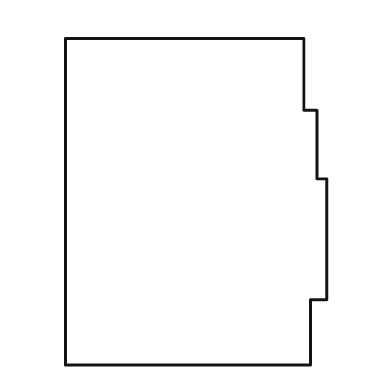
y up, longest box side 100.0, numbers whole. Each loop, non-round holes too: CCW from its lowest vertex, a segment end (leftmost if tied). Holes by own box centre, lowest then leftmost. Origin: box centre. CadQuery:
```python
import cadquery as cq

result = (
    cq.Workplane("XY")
    .moveTo(-40.0, -50.0)
    .lineTo(35.0, -50.0)
    .lineTo(35.0, -30.0)
    .lineTo(40.0, -30.0)
    .lineTo(40.0, 7.0)
    .lineTo(37.0, 7.0)
    .lineTo(37.0, 28.0)
    .lineTo(33.0, 28.0)
    .lineTo(33.0, 50.0)
    .lineTo(-40.0, 50.0)
    .close()
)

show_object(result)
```